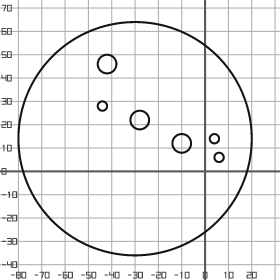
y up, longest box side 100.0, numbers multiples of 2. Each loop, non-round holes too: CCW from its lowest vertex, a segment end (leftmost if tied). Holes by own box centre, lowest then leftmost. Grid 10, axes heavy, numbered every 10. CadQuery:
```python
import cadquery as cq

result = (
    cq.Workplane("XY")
    .moveTo(-30.0, 14.0)
    .circle(50.0)
    .moveTo(6.0, 6.0)
    .circle(2.0)
    .moveTo(-10.0, 12.0)
    .circle(4.0)
    .moveTo(4.0, 14.0)
    .circle(2.0)
    .moveTo(-28.0, 22.0)
    .circle(4.0)
    .moveTo(-44.0, 28.0)
    .circle(2.0)
    .moveTo(-42.0, 46.0)
    .circle(4.0)
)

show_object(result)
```